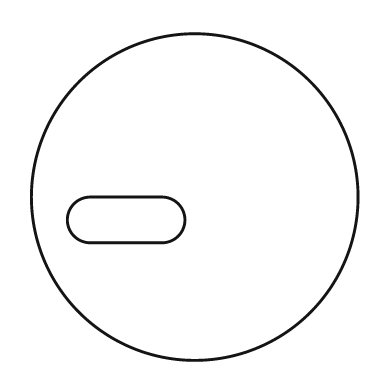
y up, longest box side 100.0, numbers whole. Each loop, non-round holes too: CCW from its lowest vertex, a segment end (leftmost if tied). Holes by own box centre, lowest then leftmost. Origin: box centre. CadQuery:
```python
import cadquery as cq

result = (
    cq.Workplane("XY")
    .moveTo(0.0, 0.0)
    .circle(50.0)
    .moveTo(-32.0, -14.0)
    .lineTo(-10.0, -14.0)
    .threePointArc((-3.0, -7.0), (-10.0, 0.0))
    .lineTo(-32.0, 0.0)
    .threePointArc((-39.0, -7.0), (-32.0, -14.0))
    .close()
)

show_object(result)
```